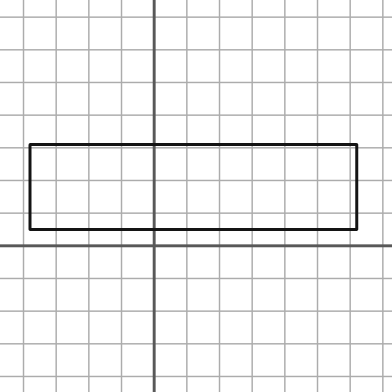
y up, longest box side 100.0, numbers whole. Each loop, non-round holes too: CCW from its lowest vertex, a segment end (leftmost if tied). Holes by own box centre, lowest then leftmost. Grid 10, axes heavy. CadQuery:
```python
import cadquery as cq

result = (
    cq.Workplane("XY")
    .moveTo(-38.0, 5.0)
    .lineTo(62.0, 5.0)
    .lineTo(62.0, 31.0)
    .lineTo(-38.0, 31.0)
    .close()
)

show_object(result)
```